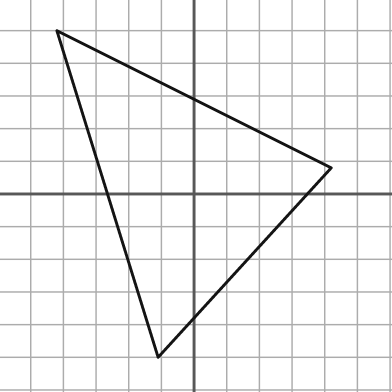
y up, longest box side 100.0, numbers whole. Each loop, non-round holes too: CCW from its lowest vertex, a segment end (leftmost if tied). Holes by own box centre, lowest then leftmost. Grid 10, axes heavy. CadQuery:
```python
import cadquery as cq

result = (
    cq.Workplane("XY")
    .moveTo(-11.0, -50.0)
    .lineTo(42.0, 8.0)
    .lineTo(-42.0, 50.0)
    .close()
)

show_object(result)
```